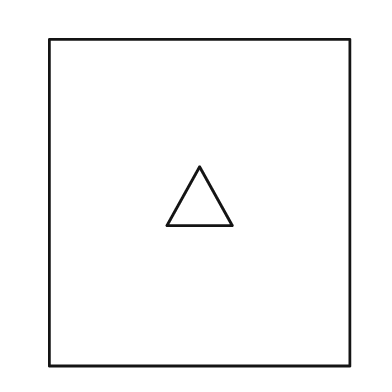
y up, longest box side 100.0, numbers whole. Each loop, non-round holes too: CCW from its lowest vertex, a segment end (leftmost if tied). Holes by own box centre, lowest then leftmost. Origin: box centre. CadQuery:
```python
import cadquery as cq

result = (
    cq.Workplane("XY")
    .moveTo(-46.0, -50.0)
    .lineTo(46.0, -50.0)
    .lineTo(46.0, 50.0)
    .lineTo(-46.0, 50.0)
    .close()
    .moveTo(-10.0, -7.0)
    .lineTo(10.0, -7.0)
    .lineTo(0.0, 11.0)
    .close()
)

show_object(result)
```